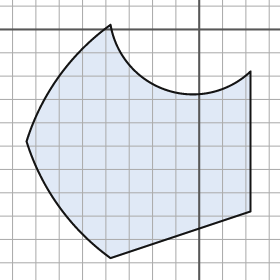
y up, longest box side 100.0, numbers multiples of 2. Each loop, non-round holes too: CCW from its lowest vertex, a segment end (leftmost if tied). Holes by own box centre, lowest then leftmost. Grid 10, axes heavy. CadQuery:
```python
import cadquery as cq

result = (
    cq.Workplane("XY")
    .moveTo(-38.0, -98.0)
    .lineTo(22.0, -78.0)
    .lineTo(22.0, -18.0)
    .threePointArc((-14.0, -26.0), (-38.0, 2.0))
    .threePointArc((-60.0, -20.0), (-74.0, -48.0))
    .threePointArc((-60.0, -76.0), (-38.0, -98.0))
    .close()
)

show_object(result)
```